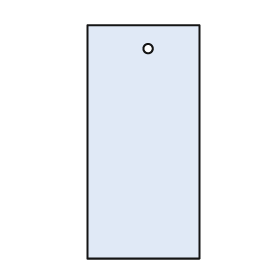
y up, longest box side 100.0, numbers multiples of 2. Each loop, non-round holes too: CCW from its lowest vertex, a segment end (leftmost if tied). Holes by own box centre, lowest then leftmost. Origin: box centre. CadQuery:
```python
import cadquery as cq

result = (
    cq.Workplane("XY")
    .moveTo(-24.0, -50.0)
    .lineTo(24.0, -50.0)
    .lineTo(24.0, 50.0)
    .lineTo(-24.0, 50.0)
    .close()
    .moveTo(2.0, 40.0)
    .circle(2.0)
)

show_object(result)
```